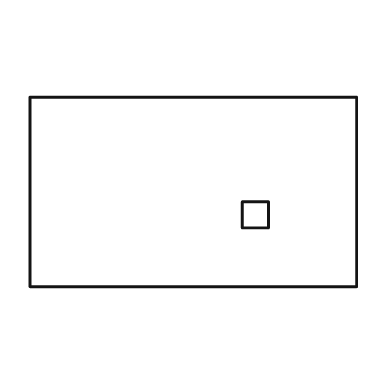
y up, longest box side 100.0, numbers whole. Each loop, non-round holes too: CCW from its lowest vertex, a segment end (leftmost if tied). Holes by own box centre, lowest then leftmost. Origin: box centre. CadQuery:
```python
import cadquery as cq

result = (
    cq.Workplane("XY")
    .moveTo(-50.0, -29.0)
    .lineTo(50.0, -29.0)
    .lineTo(50.0, 29.0)
    .lineTo(-50.0, 29.0)
    .close()
    .moveTo(15.0, -11.0)
    .lineTo(23.0, -11.0)
    .lineTo(23.0, -3.0)
    .lineTo(15.0, -3.0)
    .close()
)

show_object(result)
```